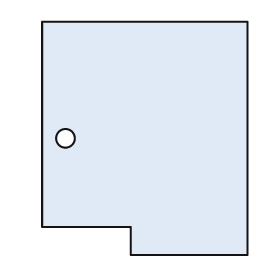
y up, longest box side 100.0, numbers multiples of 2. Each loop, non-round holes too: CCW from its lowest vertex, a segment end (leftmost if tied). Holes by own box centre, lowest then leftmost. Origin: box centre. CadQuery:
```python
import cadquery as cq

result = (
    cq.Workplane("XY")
    .moveTo(-6.0, -50.0)
    .lineTo(44.0, -50.0)
    .lineTo(44.0, 50.0)
    .lineTo(-44.0, 50.0)
    .lineTo(-44.0, -38.0)
    .lineTo(-6.0, -38.0)
    .close()
    .moveTo(-34.0, 0.0)
    .circle(4.0)
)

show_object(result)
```